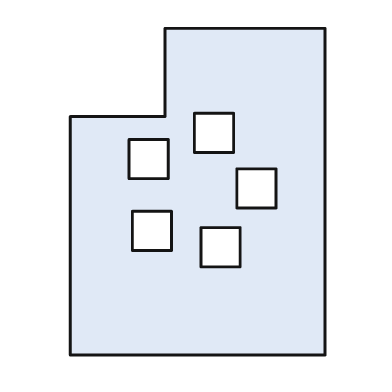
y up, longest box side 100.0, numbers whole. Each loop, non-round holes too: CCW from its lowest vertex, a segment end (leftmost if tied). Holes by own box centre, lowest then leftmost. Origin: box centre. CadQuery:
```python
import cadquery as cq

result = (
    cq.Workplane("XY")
    .moveTo(-39.0, -50.0)
    .lineTo(39.0, -50.0)
    .lineTo(39.0, 50.0)
    .lineTo(-10.0, 50.0)
    .lineTo(-10.0, 23.0)
    .lineTo(-39.0, 23.0)
    .close()
    .moveTo(1.0, -23.0)
    .lineTo(13.0, -23.0)
    .lineTo(13.0, -11.0)
    .lineTo(1.0, -11.0)
    .close()
    .moveTo(-20.0, -18.0)
    .lineTo(-8.0, -18.0)
    .lineTo(-8.0, -6.0)
    .lineTo(-20.0, -6.0)
    .close()
    .moveTo(12.0, -5.0)
    .lineTo(24.0, -5.0)
    .lineTo(24.0, 7.0)
    .lineTo(12.0, 7.0)
    .close()
    .moveTo(-21.0, 4.0)
    .lineTo(-9.0, 4.0)
    .lineTo(-9.0, 16.0)
    .lineTo(-21.0, 16.0)
    .close()
    .moveTo(-1.0, 12.0)
    .lineTo(11.0, 12.0)
    .lineTo(11.0, 24.0)
    .lineTo(-1.0, 24.0)
    .close()
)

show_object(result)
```